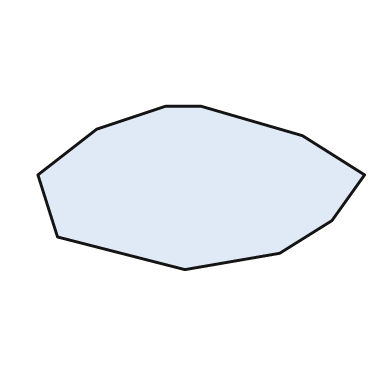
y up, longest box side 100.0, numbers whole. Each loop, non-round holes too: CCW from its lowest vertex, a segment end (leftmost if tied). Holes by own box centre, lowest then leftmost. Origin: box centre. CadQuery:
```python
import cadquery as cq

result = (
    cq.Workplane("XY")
    .moveTo(-5.0, -25.0)
    .lineTo(24.0, -20.0)
    .lineTo(40.0, -10.0)
    .lineTo(50.0, 4.0)
    .lineTo(31.0, 16.0)
    .lineTo(0.0, 25.0)
    .lineTo(-11.0, 25.0)
    .lineTo(-32.0, 18.0)
    .lineTo(-50.0, 4.0)
    .lineTo(-44.0, -15.0)
    .close()
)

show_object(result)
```